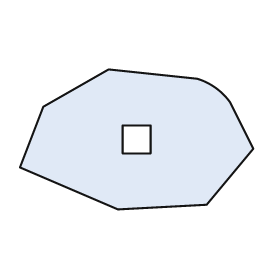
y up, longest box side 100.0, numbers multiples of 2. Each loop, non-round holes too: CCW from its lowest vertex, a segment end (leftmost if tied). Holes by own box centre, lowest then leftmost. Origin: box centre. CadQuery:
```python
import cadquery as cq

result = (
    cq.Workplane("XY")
    .moveTo(-8.0, -30.0)
    .lineTo(30.0, -28.0)
    .lineTo(50.0, -4.0)
    .lineTo(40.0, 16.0)
    .threePointArc((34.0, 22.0), (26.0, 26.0))
    .lineTo(-12.0, 30.0)
    .lineTo(-40.0, 14.0)
    .lineTo(-50.0, -12.0)
    .close()
    .moveTo(-6.0, -6.0)
    .lineTo(6.0, -6.0)
    .lineTo(6.0, 6.0)
    .lineTo(-6.0, 6.0)
    .close()
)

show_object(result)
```